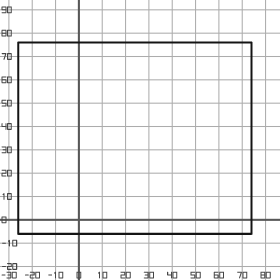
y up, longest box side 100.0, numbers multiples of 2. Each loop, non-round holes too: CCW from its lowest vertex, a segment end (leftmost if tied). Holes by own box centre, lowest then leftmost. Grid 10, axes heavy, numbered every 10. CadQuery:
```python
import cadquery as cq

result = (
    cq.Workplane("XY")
    .moveTo(-26.0, -6.0)
    .lineTo(74.0, -6.0)
    .lineTo(74.0, 76.0)
    .lineTo(-26.0, 76.0)
    .close()
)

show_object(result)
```